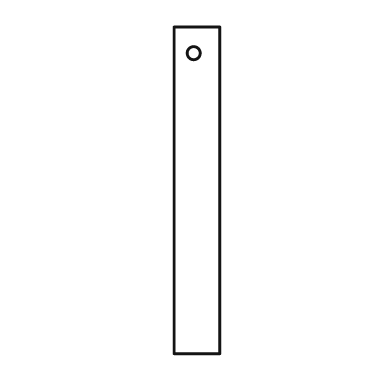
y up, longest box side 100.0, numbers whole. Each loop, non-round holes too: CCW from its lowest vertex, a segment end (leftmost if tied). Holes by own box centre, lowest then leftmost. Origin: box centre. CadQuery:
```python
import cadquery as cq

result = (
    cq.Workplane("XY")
    .moveTo(-7.0, -50.0)
    .lineTo(7.0, -50.0)
    .lineTo(7.0, 50.0)
    .lineTo(-7.0, 50.0)
    .close()
    .moveTo(-1.0, 42.0)
    .circle(2.0)
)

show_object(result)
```